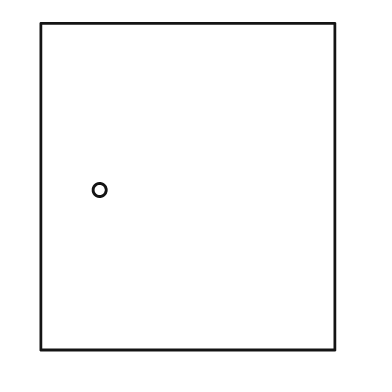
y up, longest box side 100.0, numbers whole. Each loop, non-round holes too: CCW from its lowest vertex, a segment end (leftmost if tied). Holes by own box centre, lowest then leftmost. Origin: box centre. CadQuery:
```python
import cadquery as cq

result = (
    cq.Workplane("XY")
    .moveTo(-45.0, -50.0)
    .lineTo(45.0, -50.0)
    .lineTo(45.0, 50.0)
    .lineTo(-45.0, 50.0)
    .close()
    .moveTo(-27.0, -1.0)
    .circle(2.0)
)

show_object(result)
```